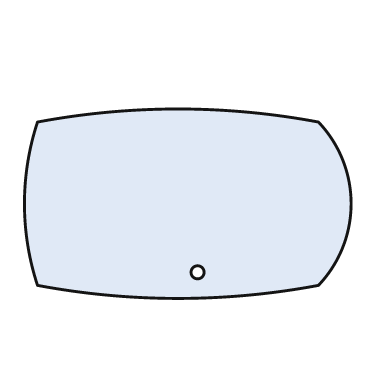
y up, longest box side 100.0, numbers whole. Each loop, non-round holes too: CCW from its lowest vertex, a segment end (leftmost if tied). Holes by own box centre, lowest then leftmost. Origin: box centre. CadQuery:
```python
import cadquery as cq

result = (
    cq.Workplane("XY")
    .moveTo(-46.0, -25.0)
    .threePointArc((-3.0, -29.0), (40.0, -25.0))
    .threePointArc((50.0, 0.0), (40.0, 25.0))
    .threePointArc((-3.0, 29.0), (-46.0, 25.0))
    .threePointArc((-50.0, 0.0), (-46.0, -25.0))
    .close()
    .moveTo(3.0, -21.0)
    .circle(2.0)
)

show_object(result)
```